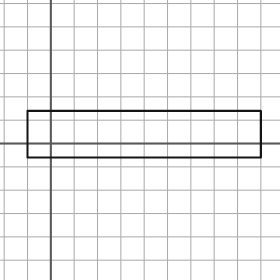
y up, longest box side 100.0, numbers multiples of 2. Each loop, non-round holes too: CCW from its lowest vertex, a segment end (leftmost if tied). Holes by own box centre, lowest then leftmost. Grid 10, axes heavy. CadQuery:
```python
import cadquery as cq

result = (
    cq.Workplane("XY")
    .moveTo(-10.0, -6.0)
    .lineTo(90.0, -6.0)
    .lineTo(90.0, 14.0)
    .lineTo(-10.0, 14.0)
    .close()
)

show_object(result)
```